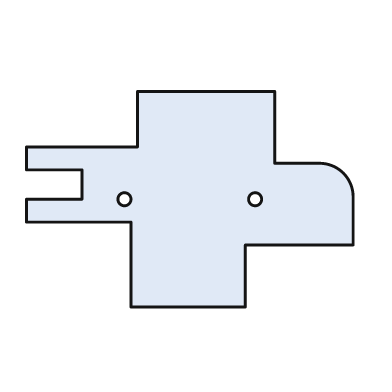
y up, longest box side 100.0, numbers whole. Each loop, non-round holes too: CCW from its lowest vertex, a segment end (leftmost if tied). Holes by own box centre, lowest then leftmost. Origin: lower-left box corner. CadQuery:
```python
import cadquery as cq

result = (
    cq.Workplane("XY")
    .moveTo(32.0, 0.0)
    .lineTo(67.0, 0.0)
    .lineTo(67.0, 19.0)
    .lineTo(100.0, 19.0)
    .lineTo(100.0, 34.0)
    .threePointArc((97.0, 41.0), (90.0, 44.0))
    .lineTo(76.0, 44.0)
    .lineTo(76.0, 66.0)
    .lineTo(34.0, 66.0)
    .lineTo(34.0, 49.0)
    .lineTo(0.0, 49.0)
    .lineTo(0.0, 42.0)
    .lineTo(17.0, 42.0)
    .lineTo(17.0, 33.0)
    .lineTo(0.0, 33.0)
    .lineTo(0.0, 26.0)
    .lineTo(32.0, 26.0)
    .close()
    .moveTo(30.0, 33.0)
    .circle(2.0)
    .moveTo(70.0, 33.0)
    .circle(2.0)
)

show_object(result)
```